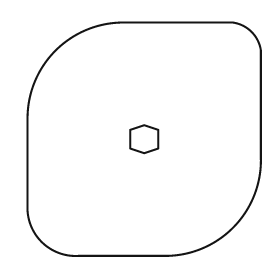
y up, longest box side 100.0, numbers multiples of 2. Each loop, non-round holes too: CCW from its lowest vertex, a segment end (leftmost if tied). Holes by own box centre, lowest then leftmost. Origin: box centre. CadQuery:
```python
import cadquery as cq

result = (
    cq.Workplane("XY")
    .moveTo(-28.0, -50.0)
    .lineTo(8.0, -50.0)
    .threePointArc((38.0, -38.0), (50.0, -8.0))
    .lineTo(50.0, 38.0)
    .threePointArc((46.0, 46.0), (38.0, 50.0))
    .lineTo(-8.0, 50.0)
    .threePointArc((-38.0, 38.0), (-50.0, 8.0))
    .lineTo(-50.0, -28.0)
    .threePointArc((-44.0, -44.0), (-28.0, -50.0))
    .close()
    .moveTo(0.0, -6.0)
    .lineTo(6.0, -4.0)
    .lineTo(6.0, 4.0)
    .lineTo(0.0, 6.0)
    .lineTo(-6.0, 4.0)
    .lineTo(-6.0, -4.0)
    .close()
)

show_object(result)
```